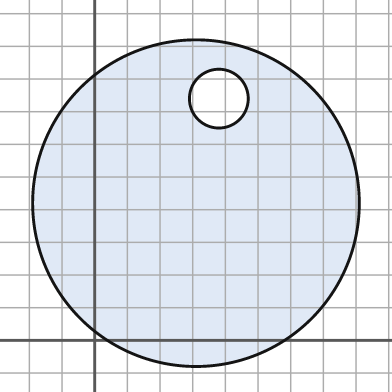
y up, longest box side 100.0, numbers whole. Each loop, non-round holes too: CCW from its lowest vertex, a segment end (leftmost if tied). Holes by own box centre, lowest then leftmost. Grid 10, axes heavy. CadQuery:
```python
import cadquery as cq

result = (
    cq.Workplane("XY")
    .moveTo(31.0, 42.0)
    .circle(50.0)
    .moveTo(38.0, 74.0)
    .circle(9.0)
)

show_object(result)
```